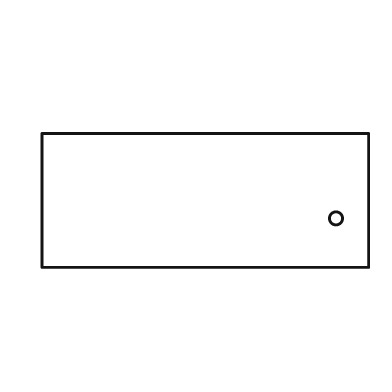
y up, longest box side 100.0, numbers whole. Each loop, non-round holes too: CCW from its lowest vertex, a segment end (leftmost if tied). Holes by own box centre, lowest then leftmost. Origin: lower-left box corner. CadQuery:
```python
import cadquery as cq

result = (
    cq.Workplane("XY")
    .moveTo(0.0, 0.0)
    .lineTo(100.0, 0.0)
    .lineTo(100.0, 41.0)
    .lineTo(0.0, 41.0)
    .close()
    .moveTo(90.0, 15.0)
    .circle(2.0)
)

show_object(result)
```